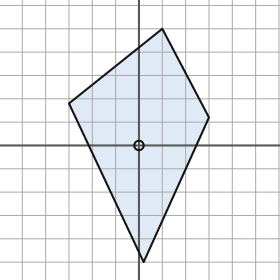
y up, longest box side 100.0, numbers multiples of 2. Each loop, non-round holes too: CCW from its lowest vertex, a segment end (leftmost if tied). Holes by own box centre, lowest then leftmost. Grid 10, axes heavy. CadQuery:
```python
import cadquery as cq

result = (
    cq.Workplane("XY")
    .moveTo(2.0, -50.0)
    .lineTo(30.0, 12.0)
    .lineTo(10.0, 50.0)
    .lineTo(-30.0, 18.0)
    .close()
    .moveTo(0.0, 0.0)
    .circle(2.0)
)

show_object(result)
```